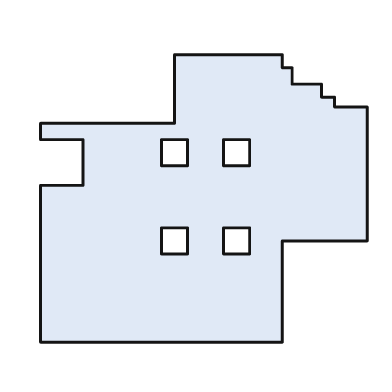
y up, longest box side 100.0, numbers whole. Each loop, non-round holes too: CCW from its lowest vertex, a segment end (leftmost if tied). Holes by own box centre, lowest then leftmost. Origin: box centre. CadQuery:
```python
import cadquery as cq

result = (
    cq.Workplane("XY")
    .moveTo(-50.0, -44.0)
    .lineTo(24.0, -44.0)
    .lineTo(24.0, -13.0)
    .lineTo(50.0, -13.0)
    .lineTo(50.0, 28.0)
    .lineTo(40.0, 28.0)
    .lineTo(40.0, 31.0)
    .lineTo(36.0, 31.0)
    .lineTo(36.0, 35.0)
    .lineTo(27.0, 35.0)
    .lineTo(27.0, 40.0)
    .lineTo(24.0, 40.0)
    .lineTo(24.0, 44.0)
    .lineTo(-9.0, 44.0)
    .lineTo(-9.0, 23.0)
    .lineTo(-50.0, 23.0)
    .lineTo(-50.0, 18.0)
    .lineTo(-37.0, 18.0)
    .lineTo(-37.0, 4.0)
    .lineTo(-50.0, 4.0)
    .close()
    .moveTo(-13.0, -17.0)
    .lineTo(-5.0, -17.0)
    .lineTo(-5.0, -9.0)
    .lineTo(-13.0, -9.0)
    .close()
    .moveTo(6.0, -17.0)
    .lineTo(14.0, -17.0)
    .lineTo(14.0, -9.0)
    .lineTo(6.0, -9.0)
    .close()
    .moveTo(-13.0, 10.0)
    .lineTo(-5.0, 10.0)
    .lineTo(-5.0, 18.0)
    .lineTo(-13.0, 18.0)
    .close()
    .moveTo(6.0, 10.0)
    .lineTo(14.0, 10.0)
    .lineTo(14.0, 18.0)
    .lineTo(6.0, 18.0)
    .close()
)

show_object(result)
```